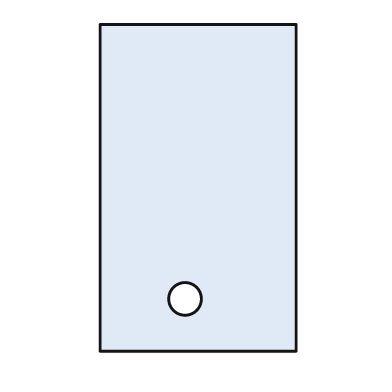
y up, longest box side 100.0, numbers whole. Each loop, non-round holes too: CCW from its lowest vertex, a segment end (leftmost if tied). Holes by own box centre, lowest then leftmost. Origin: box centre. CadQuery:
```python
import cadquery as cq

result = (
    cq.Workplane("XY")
    .moveTo(-30.0, -50.0)
    .lineTo(30.0, -50.0)
    .lineTo(30.0, 50.0)
    .lineTo(-30.0, 50.0)
    .close()
    .moveTo(-4.0, -34.0)
    .circle(5.0)
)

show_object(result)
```